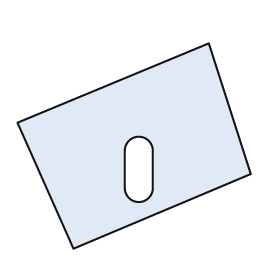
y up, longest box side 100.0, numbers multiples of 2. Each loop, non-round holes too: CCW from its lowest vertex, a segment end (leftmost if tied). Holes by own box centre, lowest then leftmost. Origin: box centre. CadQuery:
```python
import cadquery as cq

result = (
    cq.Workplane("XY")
    .moveTo(-26.0, -44.0)
    .lineTo(50.0, -12.0)
    .lineTo(32.0, 44.0)
    .lineTo(-50.0, 10.0)
    .close()
    .moveTo(-4.0, -18.0)
    .threePointArc((2.0, -24.0), (8.0, -18.0))
    .lineTo(8.0, -2.0)
    .threePointArc((2.0, 4.0), (-4.0, -2.0))
    .close()
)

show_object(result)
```